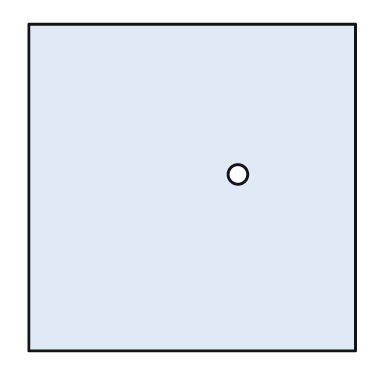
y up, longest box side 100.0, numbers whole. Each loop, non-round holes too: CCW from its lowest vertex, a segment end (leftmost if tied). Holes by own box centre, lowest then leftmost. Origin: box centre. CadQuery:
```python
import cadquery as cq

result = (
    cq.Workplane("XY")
    .moveTo(-50.0, -50.0)
    .lineTo(50.0, -50.0)
    .lineTo(50.0, 50.0)
    .lineTo(-50.0, 50.0)
    .close()
    .moveTo(14.0, 4.0)
    .circle(3.0)
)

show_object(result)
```